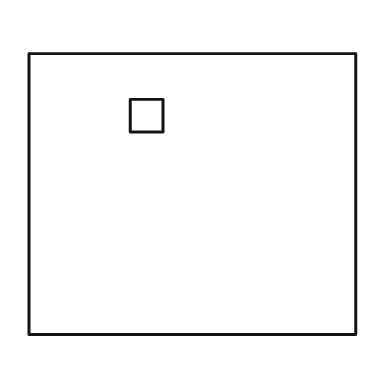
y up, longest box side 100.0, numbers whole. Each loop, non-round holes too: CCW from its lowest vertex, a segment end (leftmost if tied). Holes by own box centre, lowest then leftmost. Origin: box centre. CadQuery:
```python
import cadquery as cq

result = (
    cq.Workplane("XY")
    .moveTo(-50.0, -43.0)
    .lineTo(50.0, -43.0)
    .lineTo(50.0, 43.0)
    .lineTo(-50.0, 43.0)
    .close()
    .moveTo(-19.0, 19.0)
    .lineTo(-9.0, 19.0)
    .lineTo(-9.0, 29.0)
    .lineTo(-19.0, 29.0)
    .close()
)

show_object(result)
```